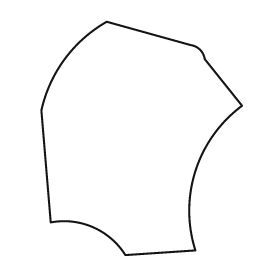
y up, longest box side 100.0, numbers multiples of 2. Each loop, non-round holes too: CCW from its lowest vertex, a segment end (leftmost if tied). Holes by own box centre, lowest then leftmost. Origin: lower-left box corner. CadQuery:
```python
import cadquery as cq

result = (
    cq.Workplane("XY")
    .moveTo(36.0, 0.0)
    .lineTo(66.0, 2.0)
    .threePointArc((66.0, 36.0), (86.0, 64.0))
    .lineTo(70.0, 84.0)
    .threePointArc((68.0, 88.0), (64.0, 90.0))
    .lineTo(28.0, 100.0)
    .threePointArc((10.0, 84.0), (0.0, 62.0))
    .lineTo(4.0, 14.0)
    .threePointArc((22.0, 12.0), (36.0, 0.0))
    .close()
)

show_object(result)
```